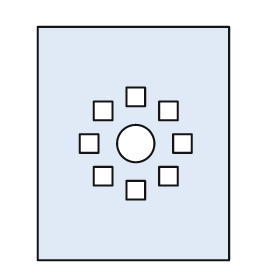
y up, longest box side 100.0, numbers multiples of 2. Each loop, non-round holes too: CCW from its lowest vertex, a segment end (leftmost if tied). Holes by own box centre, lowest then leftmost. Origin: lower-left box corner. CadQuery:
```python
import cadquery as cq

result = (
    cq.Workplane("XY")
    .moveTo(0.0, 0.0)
    .lineTo(82.0, 0.0)
    .lineTo(82.0, 100.0)
    .lineTo(0.0, 100.0)
    .close()
    .moveTo(38.0, 26.0)
    .lineTo(46.0, 26.0)
    .lineTo(46.0, 34.0)
    .lineTo(38.0, 34.0)
    .close()
    .moveTo(24.0, 32.0)
    .lineTo(32.0, 32.0)
    .lineTo(32.0, 40.0)
    .lineTo(24.0, 40.0)
    .close()
    .moveTo(52.0, 32.0)
    .lineTo(60.0, 32.0)
    .lineTo(60.0, 40.0)
    .lineTo(52.0, 40.0)
    .close()
    .moveTo(18.0, 46.0)
    .lineTo(26.0, 46.0)
    .lineTo(26.0, 54.0)
    .lineTo(18.0, 54.0)
    .close()
    .moveTo(42.0, 50.0)
    .circle(8.0)
    .moveTo(58.0, 46.0)
    .lineTo(66.0, 46.0)
    .lineTo(66.0, 54.0)
    .lineTo(58.0, 54.0)
    .close()
    .moveTo(24.0, 60.0)
    .lineTo(32.0, 60.0)
    .lineTo(32.0, 68.0)
    .lineTo(24.0, 68.0)
    .close()
    .moveTo(52.0, 60.0)
    .lineTo(60.0, 60.0)
    .lineTo(60.0, 68.0)
    .lineTo(52.0, 68.0)
    .close()
    .moveTo(38.0, 66.0)
    .lineTo(46.0, 66.0)
    .lineTo(46.0, 74.0)
    .lineTo(38.0, 74.0)
    .close()
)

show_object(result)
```